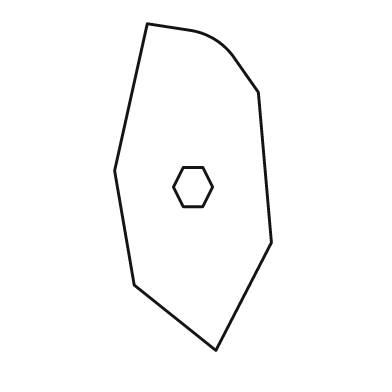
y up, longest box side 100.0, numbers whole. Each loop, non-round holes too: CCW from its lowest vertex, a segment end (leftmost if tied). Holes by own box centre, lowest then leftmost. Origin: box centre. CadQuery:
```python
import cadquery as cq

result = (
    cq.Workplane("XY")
    .moveTo(7.0, -50.0)
    .lineTo(24.0, -17.0)
    .lineTo(20.0, 29.0)
    .lineTo(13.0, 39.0)
    .threePointArc((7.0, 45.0), (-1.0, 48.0))
    .lineTo(-14.0, 50.0)
    .lineTo(-24.0, 5.0)
    .lineTo(-18.0, -30.0)
    .close()
    .moveTo(-3.0, -6.0)
    .lineTo(3.0, -6.0)
    .lineTo(6.0, 0.0)
    .lineTo(3.0, 6.0)
    .lineTo(-3.0, 6.0)
    .lineTo(-6.0, 0.0)
    .close()
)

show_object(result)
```